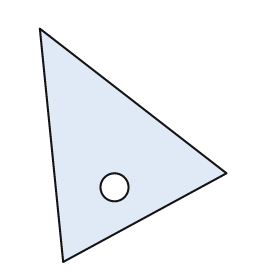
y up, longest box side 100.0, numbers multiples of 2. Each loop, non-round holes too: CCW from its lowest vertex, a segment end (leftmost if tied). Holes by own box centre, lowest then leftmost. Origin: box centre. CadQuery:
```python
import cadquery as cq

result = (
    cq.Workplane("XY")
    .moveTo(-30.0, -50.0)
    .lineTo(40.0, -12.0)
    .lineTo(-40.0, 50.0)
    .close()
    .moveTo(-8.0, -18.0)
    .circle(6.0)
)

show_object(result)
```